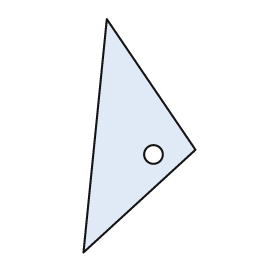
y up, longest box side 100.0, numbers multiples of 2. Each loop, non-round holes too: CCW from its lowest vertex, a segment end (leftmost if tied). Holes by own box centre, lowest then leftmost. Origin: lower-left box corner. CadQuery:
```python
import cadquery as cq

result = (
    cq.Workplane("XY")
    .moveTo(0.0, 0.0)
    .lineTo(48.0, 44.0)
    .lineTo(10.0, 100.0)
    .close()
    .moveTo(30.0, 42.0)
    .circle(4.0)
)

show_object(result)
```